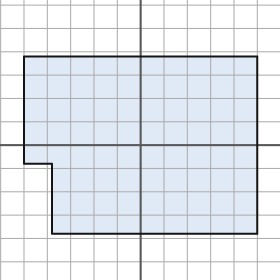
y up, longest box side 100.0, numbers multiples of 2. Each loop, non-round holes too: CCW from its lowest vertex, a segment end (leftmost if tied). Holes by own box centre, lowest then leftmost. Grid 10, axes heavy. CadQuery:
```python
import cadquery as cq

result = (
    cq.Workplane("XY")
    .moveTo(-38.0, -38.0)
    .lineTo(50.0, -38.0)
    .lineTo(50.0, 38.0)
    .lineTo(-50.0, 38.0)
    .lineTo(-50.0, -8.0)
    .lineTo(-38.0, -8.0)
    .close()
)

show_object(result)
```